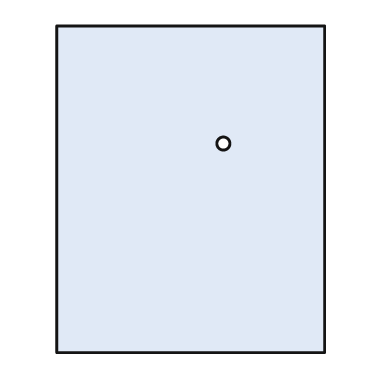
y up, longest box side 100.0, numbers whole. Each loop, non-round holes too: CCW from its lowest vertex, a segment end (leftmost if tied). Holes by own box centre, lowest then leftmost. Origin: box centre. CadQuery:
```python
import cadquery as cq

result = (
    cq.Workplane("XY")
    .moveTo(-41.0, -50.0)
    .lineTo(41.0, -50.0)
    .lineTo(41.0, 50.0)
    .lineTo(-41.0, 50.0)
    .close()
    .moveTo(10.0, 14.0)
    .circle(2.0)
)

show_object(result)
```